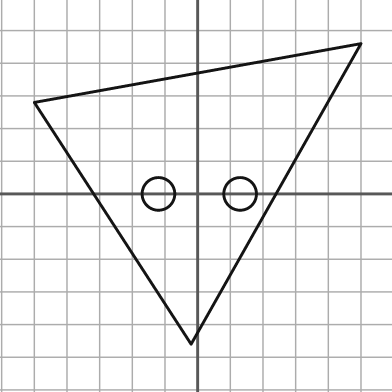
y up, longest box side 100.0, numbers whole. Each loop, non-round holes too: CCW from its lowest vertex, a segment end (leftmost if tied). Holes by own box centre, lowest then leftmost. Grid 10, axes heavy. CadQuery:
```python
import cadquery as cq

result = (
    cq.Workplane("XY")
    .moveTo(-2.0, -46.0)
    .lineTo(50.0, 46.0)
    .lineTo(-50.0, 28.0)
    .close()
    .moveTo(-12.0, 0.0)
    .circle(5.0)
    .moveTo(13.0, 0.0)
    .circle(5.0)
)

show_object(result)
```